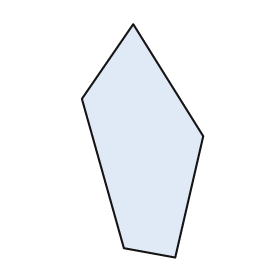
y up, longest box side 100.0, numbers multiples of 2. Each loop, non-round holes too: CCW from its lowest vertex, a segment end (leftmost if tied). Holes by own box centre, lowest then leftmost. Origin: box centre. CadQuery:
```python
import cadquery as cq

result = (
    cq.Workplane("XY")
    .moveTo(14.0, -50.0)
    .lineTo(26.0, 2.0)
    .lineTo(-4.0, 50.0)
    .lineTo(-26.0, 18.0)
    .lineTo(-8.0, -46.0)
    .close()
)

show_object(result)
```